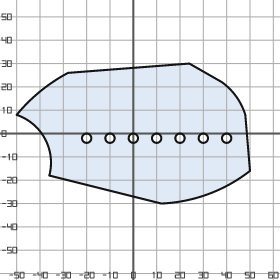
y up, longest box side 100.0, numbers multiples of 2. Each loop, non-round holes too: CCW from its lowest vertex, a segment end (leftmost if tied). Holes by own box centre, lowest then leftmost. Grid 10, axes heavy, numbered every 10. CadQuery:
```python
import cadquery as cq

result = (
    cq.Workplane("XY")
    .moveTo(12.0, -30.0)
    .threePointArc((32.0, -26.0), (50.0, -16.0))
    .lineTo(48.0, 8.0)
    .threePointArc((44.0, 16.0), (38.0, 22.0))
    .lineTo(24.0, 30.0)
    .lineTo(-28.0, 26.0)
    .threePointArc((-40.0, 18.0), (-50.0, 8.0))
    .threePointArc((-38.0, -2.0), (-36.0, -18.0))
    .close()
    .moveTo(-20.0, -2.0)
    .circle(2.0)
    .moveTo(-10.0, -2.0)
    .circle(2.0)
    .moveTo(0.0, -2.0)
    .circle(2.0)
    .moveTo(10.0, -2.0)
    .circle(2.0)
    .moveTo(20.0, -2.0)
    .circle(2.0)
    .moveTo(30.0, -2.0)
    .circle(2.0)
    .moveTo(40.0, -2.0)
    .circle(2.0)
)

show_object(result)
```